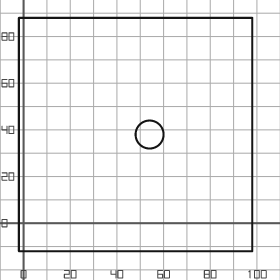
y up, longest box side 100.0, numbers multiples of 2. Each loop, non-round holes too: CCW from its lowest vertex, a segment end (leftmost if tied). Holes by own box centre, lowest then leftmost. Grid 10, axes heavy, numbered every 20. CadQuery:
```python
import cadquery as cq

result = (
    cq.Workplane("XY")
    .moveTo(-2.0, -12.0)
    .lineTo(98.0, -12.0)
    .lineTo(98.0, 88.0)
    .lineTo(-2.0, 88.0)
    .close()
    .moveTo(54.0, 38.0)
    .circle(6.0)
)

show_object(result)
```